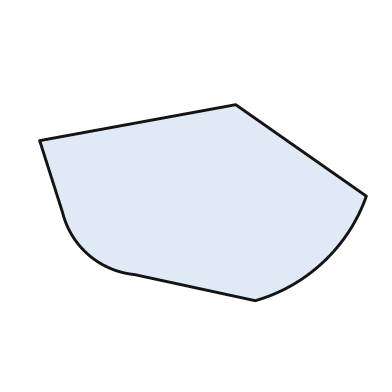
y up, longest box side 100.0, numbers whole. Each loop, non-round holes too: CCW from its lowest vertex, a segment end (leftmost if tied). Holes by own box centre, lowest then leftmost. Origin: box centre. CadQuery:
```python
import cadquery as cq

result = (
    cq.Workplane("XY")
    .moveTo(16.0, -30.0)
    .threePointArc((37.0, -18.0), (50.0, 2.0))
    .lineTo(10.0, 30.0)
    .lineTo(-50.0, 19.0)
    .lineTo(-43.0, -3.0)
    .threePointArc((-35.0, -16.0), (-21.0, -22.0))
    .close()
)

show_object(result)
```